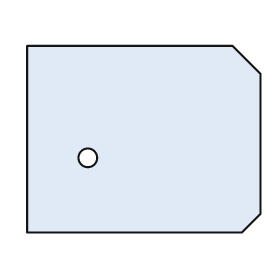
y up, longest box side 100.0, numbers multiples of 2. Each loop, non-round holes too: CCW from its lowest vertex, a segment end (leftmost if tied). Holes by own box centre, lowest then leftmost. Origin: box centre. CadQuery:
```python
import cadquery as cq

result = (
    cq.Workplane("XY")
    .moveTo(-50.0, -40.0)
    .lineTo(42.0, -40.0)
    .lineTo(50.0, -32.0)
    .lineTo(50.0, 28.0)
    .lineTo(38.0, 40.0)
    .lineTo(-50.0, 40.0)
    .close()
    .moveTo(-24.0, -8.0)
    .circle(4.0)
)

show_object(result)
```